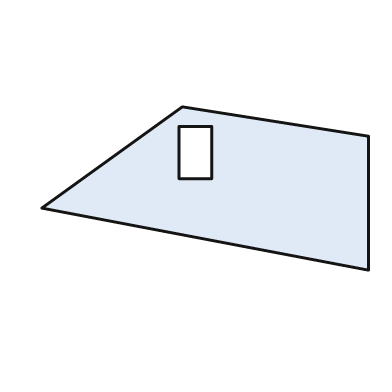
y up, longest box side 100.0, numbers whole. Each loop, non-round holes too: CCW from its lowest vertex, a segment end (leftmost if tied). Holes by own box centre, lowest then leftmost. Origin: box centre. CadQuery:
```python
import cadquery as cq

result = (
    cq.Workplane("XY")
    .moveTo(50.0, -25.0)
    .lineTo(50.0, 16.0)
    .lineTo(-7.0, 25.0)
    .lineTo(-50.0, -6.0)
    .close()
    .moveTo(-8.0, 3.0)
    .lineTo(2.0, 3.0)
    .lineTo(2.0, 19.0)
    .lineTo(-8.0, 19.0)
    .close()
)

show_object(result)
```